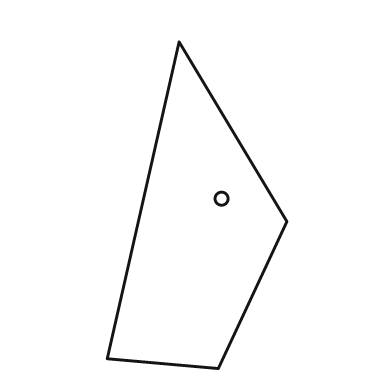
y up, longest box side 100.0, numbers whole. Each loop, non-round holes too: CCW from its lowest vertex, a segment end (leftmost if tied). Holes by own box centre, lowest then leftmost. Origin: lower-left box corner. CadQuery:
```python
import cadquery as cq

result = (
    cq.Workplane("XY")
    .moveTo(34.0, 0.0)
    .lineTo(55.0, 45.0)
    .lineTo(22.0, 100.0)
    .lineTo(0.0, 3.0)
    .close()
    .moveTo(35.0, 52.0)
    .circle(2.0)
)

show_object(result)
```